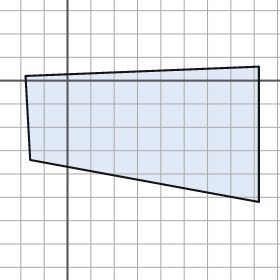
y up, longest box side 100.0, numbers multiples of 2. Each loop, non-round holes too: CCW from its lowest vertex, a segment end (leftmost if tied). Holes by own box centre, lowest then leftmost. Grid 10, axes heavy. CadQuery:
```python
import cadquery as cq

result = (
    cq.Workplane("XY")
    .moveTo(82.0, -52.0)
    .lineTo(82.0, 6.0)
    .lineTo(-18.0, 2.0)
    .lineTo(-16.0, -34.0)
    .close()
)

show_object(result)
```